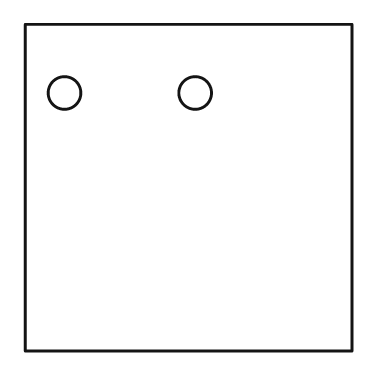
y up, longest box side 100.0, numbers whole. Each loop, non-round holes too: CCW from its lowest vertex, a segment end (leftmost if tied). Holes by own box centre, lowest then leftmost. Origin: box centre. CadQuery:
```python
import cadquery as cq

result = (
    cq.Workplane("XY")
    .moveTo(-50.0, -50.0)
    .lineTo(50.0, -50.0)
    .lineTo(50.0, 50.0)
    .lineTo(-50.0, 50.0)
    .close()
    .moveTo(-38.0, 29.0)
    .circle(5.0)
    .moveTo(2.0, 29.0)
    .circle(5.0)
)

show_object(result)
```